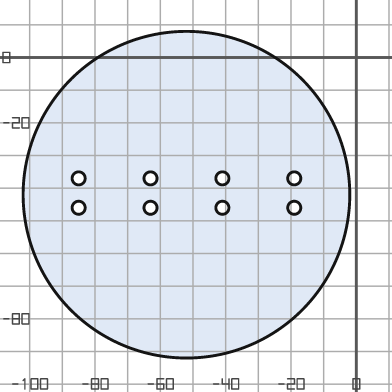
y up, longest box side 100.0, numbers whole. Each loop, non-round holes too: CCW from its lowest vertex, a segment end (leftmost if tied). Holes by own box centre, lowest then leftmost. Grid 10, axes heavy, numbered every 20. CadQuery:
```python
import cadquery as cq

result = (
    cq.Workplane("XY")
    .moveTo(-52.0, -42.0)
    .circle(50.0)
    .moveTo(-85.0, -46.0)
    .circle(2.0)
    .moveTo(-63.0, -46.0)
    .circle(2.0)
    .moveTo(-41.0, -46.0)
    .circle(2.0)
    .moveTo(-19.0, -46.0)
    .circle(2.0)
    .moveTo(-85.0, -37.0)
    .circle(2.0)
    .moveTo(-63.0, -37.0)
    .circle(2.0)
    .moveTo(-41.0, -37.0)
    .circle(2.0)
    .moveTo(-19.0, -37.0)
    .circle(2.0)
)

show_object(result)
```